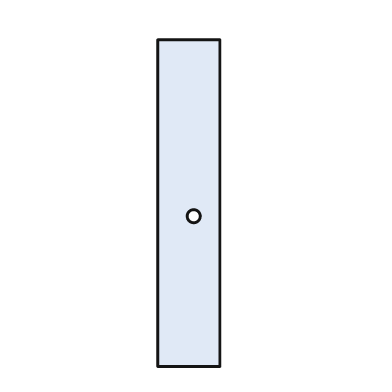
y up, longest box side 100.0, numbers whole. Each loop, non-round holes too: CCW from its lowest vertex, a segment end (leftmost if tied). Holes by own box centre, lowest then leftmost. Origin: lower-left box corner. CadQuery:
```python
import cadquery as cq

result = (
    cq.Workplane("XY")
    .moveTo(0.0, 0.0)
    .lineTo(19.0, 0.0)
    .lineTo(19.0, 100.0)
    .lineTo(0.0, 100.0)
    .close()
    .moveTo(11.0, 46.0)
    .circle(2.0)
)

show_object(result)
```